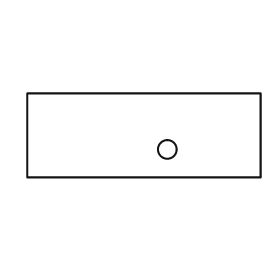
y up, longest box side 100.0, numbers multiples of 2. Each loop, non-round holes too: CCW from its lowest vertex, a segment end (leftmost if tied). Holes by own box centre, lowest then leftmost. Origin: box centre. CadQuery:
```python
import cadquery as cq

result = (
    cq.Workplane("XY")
    .moveTo(-50.0, -18.0)
    .lineTo(50.0, -18.0)
    .lineTo(50.0, 18.0)
    .lineTo(-50.0, 18.0)
    .close()
    .moveTo(10.0, -6.0)
    .circle(4.0)
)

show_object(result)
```